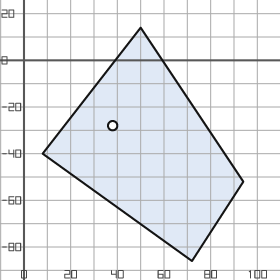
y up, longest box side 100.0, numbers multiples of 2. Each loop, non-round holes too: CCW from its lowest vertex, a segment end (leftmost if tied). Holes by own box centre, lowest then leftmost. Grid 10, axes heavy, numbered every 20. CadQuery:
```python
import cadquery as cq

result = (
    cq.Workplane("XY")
    .moveTo(72.0, -86.0)
    .lineTo(94.0, -52.0)
    .lineTo(50.0, 14.0)
    .lineTo(8.0, -40.0)
    .close()
    .moveTo(38.0, -28.0)
    .circle(2.0)
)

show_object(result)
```